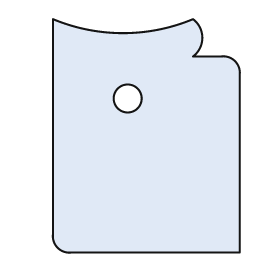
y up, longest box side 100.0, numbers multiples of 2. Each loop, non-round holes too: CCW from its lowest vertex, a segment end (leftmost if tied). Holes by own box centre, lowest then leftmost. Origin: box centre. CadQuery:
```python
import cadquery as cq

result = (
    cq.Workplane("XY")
    .moveTo(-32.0, -50.0)
    .lineTo(40.0, -50.0)
    .lineTo(40.0, 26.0)
    .threePointArc((38.0, 32.0), (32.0, 34.0))
    .lineTo(20.0, 34.0)
    .threePointArc((24.0, 42.0), (20.0, 50.0))
    .threePointArc((-10.0, 44.0), (-40.0, 50.0))
    .lineTo(-40.0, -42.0)
    .threePointArc((-38.0, -48.0), (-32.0, -50.0))
    .close()
    .moveTo(-8.0, 16.0)
    .circle(6.0)
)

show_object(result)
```